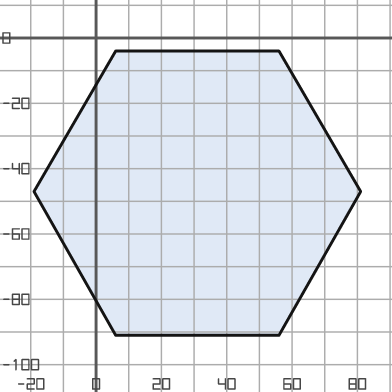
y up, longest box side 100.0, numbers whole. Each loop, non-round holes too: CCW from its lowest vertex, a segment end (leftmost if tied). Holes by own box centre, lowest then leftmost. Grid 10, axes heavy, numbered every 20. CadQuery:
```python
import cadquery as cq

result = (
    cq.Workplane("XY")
    .moveTo(6.0, -91.0)
    .lineTo(56.0, -91.0)
    .lineTo(81.0, -47.0)
    .lineTo(56.0, -4.0)
    .lineTo(6.0, -4.0)
    .lineTo(-19.0, -47.0)
    .close()
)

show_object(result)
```